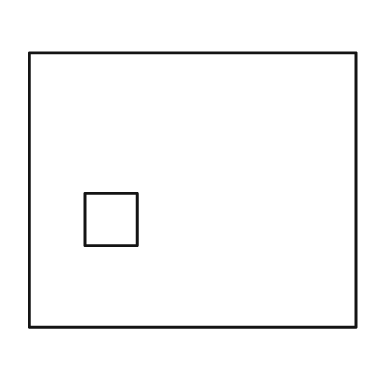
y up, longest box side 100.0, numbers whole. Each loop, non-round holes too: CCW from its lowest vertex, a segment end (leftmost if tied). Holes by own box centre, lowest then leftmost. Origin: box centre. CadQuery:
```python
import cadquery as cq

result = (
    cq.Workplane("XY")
    .moveTo(-50.0, -42.0)
    .lineTo(50.0, -42.0)
    .lineTo(50.0, 42.0)
    .lineTo(-50.0, 42.0)
    .close()
    .moveTo(-33.0, -17.0)
    .lineTo(-17.0, -17.0)
    .lineTo(-17.0, -1.0)
    .lineTo(-33.0, -1.0)
    .close()
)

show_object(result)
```